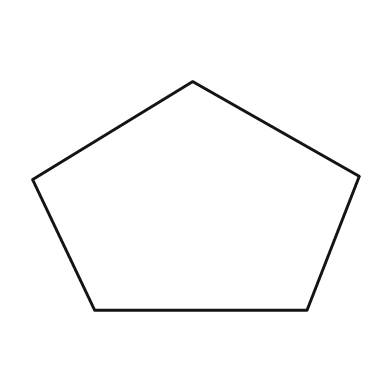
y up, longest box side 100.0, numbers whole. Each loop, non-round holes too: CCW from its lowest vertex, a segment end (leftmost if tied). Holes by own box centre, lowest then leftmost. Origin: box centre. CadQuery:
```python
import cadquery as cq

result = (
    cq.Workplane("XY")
    .moveTo(-31.0, -35.0)
    .lineTo(34.0, -35.0)
    .lineTo(50.0, 6.0)
    .lineTo(-1.0, 35.0)
    .lineTo(-50.0, 5.0)
    .close()
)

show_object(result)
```